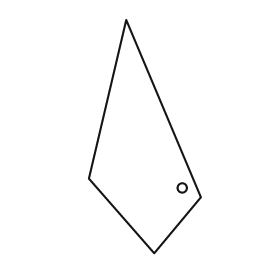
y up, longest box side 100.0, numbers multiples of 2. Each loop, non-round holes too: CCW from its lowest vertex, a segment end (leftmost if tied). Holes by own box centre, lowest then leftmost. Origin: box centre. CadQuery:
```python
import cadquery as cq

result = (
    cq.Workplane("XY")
    .moveTo(4.0, -50.0)
    .lineTo(24.0, -26.0)
    .lineTo(-8.0, 50.0)
    .lineTo(-24.0, -18.0)
    .close()
    .moveTo(16.0, -22.0)
    .circle(2.0)
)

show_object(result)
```